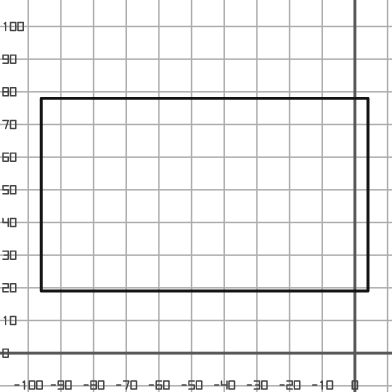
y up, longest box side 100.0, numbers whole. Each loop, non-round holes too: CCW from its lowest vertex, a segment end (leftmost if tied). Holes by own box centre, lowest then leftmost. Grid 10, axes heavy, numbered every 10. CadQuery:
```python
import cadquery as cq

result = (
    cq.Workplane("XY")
    .moveTo(-96.0, 19.0)
    .lineTo(4.0, 19.0)
    .lineTo(4.0, 78.0)
    .lineTo(-96.0, 78.0)
    .close()
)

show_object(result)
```